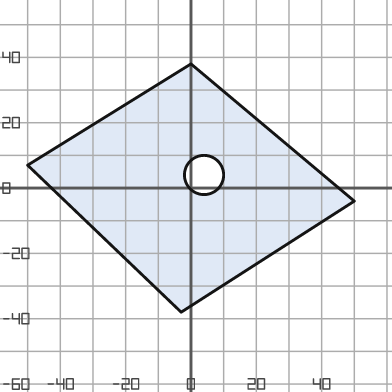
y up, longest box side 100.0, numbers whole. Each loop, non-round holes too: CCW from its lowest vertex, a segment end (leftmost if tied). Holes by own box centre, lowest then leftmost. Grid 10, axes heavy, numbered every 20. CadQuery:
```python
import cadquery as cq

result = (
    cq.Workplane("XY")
    .moveTo(-3.0, -38.0)
    .lineTo(50.0, -4.0)
    .lineTo(0.0, 38.0)
    .lineTo(-50.0, 7.0)
    .close()
    .moveTo(4.0, 4.0)
    .circle(6.0)
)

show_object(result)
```